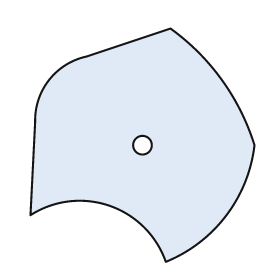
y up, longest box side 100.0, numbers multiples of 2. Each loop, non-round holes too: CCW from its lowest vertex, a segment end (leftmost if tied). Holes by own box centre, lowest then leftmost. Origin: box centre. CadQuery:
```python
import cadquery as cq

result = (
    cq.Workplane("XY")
    .moveTo(10.0, -50.0)
    .threePointArc((36.0, -30.0), (48.0, 0.0))
    .threePointArc((34.0, 28.0), (12.0, 50.0))
    .lineTo(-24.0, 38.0)
    .threePointArc((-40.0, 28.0), (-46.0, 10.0))
    .lineTo(-48.0, -30.0)
    .threePointArc((-14.0, -26.0), (10.0, -50.0))
    .close()
    .moveTo(0.0, 0.0)
    .circle(4.0)
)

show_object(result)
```